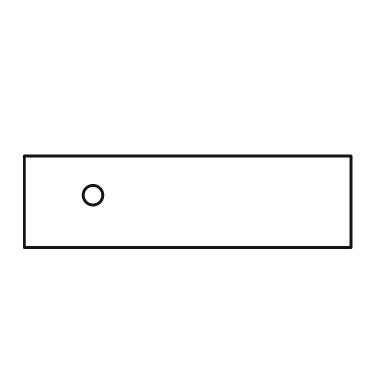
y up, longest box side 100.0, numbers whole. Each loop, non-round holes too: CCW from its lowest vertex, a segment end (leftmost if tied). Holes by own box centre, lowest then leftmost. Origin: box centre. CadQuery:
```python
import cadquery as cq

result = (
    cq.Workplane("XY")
    .moveTo(-50.0, -14.0)
    .lineTo(50.0, -14.0)
    .lineTo(50.0, 14.0)
    .lineTo(-50.0, 14.0)
    .close()
    .moveTo(-29.0, 2.0)
    .circle(3.0)
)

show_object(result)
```